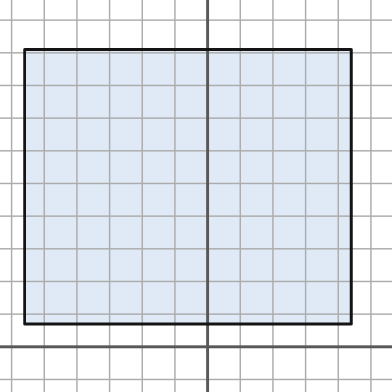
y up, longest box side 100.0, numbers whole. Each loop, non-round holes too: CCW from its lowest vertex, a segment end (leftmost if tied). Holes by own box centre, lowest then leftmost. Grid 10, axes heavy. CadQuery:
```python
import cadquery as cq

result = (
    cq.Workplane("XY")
    .moveTo(-56.0, 7.0)
    .lineTo(44.0, 7.0)
    .lineTo(44.0, 91.0)
    .lineTo(-56.0, 91.0)
    .close()
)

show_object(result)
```